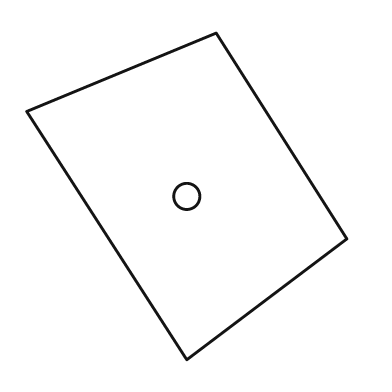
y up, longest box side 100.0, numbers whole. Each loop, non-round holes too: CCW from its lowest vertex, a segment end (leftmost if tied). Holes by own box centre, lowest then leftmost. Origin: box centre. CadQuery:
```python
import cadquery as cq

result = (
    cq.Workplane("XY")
    .moveTo(0.0, -50.0)
    .lineTo(49.0, -13.0)
    .lineTo(9.0, 50.0)
    .lineTo(-49.0, 26.0)
    .close()
    .moveTo(0.0, 0.0)
    .circle(4.0)
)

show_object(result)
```